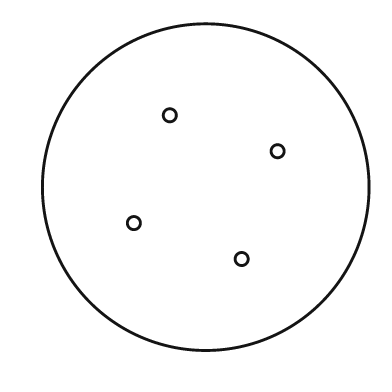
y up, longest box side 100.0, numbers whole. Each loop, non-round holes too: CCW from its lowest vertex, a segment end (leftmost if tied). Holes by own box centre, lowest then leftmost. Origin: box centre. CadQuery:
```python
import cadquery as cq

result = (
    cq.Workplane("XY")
    .moveTo(0.0, 0.0)
    .circle(50.0)
    .moveTo(11.0, -22.0)
    .circle(2.0)
    .moveTo(-22.0, -11.0)
    .circle(2.0)
    .moveTo(22.0, 11.0)
    .circle(2.0)
    .moveTo(-11.0, 22.0)
    .circle(2.0)
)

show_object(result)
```